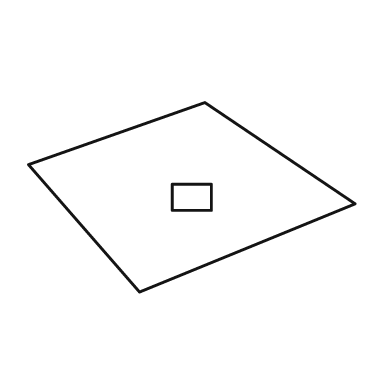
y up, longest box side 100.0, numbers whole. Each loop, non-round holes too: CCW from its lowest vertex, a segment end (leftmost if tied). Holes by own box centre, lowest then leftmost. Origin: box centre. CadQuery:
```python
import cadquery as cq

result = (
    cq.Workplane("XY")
    .moveTo(-16.0, -29.0)
    .lineTo(50.0, -2.0)
    .lineTo(4.0, 29.0)
    .lineTo(-50.0, 10.0)
    .close()
    .moveTo(-6.0, -4.0)
    .lineTo(6.0, -4.0)
    .lineTo(6.0, 4.0)
    .lineTo(-6.0, 4.0)
    .close()
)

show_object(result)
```